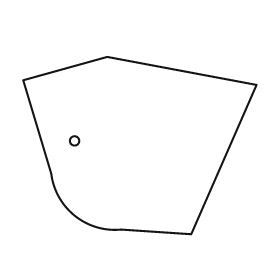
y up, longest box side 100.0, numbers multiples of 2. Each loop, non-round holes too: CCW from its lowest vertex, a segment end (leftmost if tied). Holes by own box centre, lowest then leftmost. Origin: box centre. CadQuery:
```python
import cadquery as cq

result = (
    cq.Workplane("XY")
    .moveTo(22.0, -38.0)
    .lineTo(50.0, 26.0)
    .lineTo(-14.0, 38.0)
    .lineTo(-50.0, 28.0)
    .lineTo(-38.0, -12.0)
    .threePointArc((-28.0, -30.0), (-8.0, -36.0))
    .close()
    .moveTo(-28.0, 2.0)
    .circle(2.0)
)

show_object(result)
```